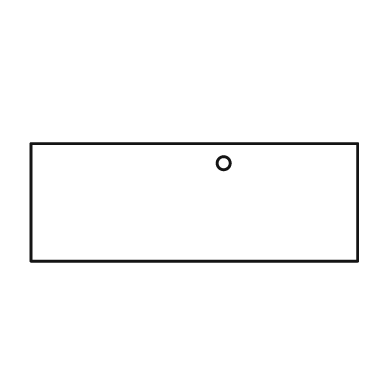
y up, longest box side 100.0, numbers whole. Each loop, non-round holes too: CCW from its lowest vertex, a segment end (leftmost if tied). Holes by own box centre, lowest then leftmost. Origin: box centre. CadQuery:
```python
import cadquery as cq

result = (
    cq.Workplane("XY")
    .moveTo(-50.0, -18.0)
    .lineTo(50.0, -18.0)
    .lineTo(50.0, 18.0)
    .lineTo(-50.0, 18.0)
    .close()
    .moveTo(9.0, 12.0)
    .circle(2.0)
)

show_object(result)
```